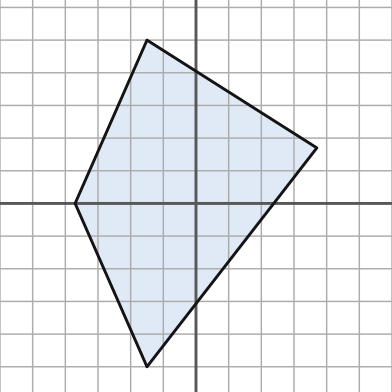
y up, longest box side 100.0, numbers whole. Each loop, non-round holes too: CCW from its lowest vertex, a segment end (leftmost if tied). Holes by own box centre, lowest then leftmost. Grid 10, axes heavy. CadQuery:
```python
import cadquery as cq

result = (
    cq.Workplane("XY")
    .moveTo(-15.0, -50.0)
    .lineTo(37.0, 17.0)
    .lineTo(-15.0, 50.0)
    .lineTo(-37.0, 0.0)
    .close()
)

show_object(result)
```